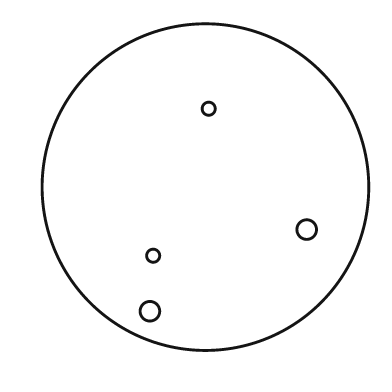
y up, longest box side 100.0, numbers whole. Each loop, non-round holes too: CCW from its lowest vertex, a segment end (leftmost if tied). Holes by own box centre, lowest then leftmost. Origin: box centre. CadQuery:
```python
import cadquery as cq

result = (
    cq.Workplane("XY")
    .moveTo(0.0, 0.0)
    .circle(50.0)
    .moveTo(-17.0, -38.0)
    .circle(3.0)
    .moveTo(-16.0, -21.0)
    .circle(2.0)
    .moveTo(31.0, -13.0)
    .circle(3.0)
    .moveTo(1.0, 24.0)
    .circle(2.0)
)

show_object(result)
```